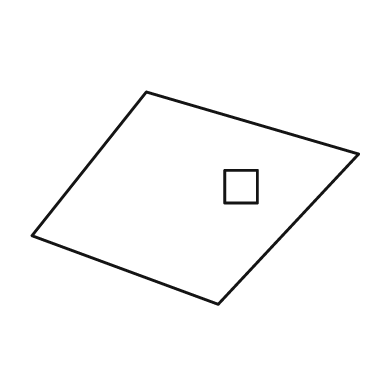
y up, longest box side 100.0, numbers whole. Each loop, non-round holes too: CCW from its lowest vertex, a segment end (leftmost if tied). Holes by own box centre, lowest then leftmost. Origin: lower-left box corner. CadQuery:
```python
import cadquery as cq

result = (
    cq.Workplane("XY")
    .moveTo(57.0, 0.0)
    .lineTo(100.0, 46.0)
    .lineTo(35.0, 65.0)
    .lineTo(0.0, 21.0)
    .close()
    .moveTo(59.0, 31.0)
    .lineTo(69.0, 31.0)
    .lineTo(69.0, 41.0)
    .lineTo(59.0, 41.0)
    .close()
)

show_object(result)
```